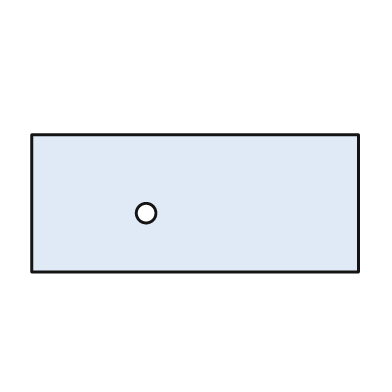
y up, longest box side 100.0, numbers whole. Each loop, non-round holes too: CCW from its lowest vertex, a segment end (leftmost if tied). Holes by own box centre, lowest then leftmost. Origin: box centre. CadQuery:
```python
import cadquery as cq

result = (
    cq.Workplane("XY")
    .moveTo(-50.0, -21.0)
    .lineTo(50.0, -21.0)
    .lineTo(50.0, 21.0)
    .lineTo(-50.0, 21.0)
    .close()
    .moveTo(-15.0, -3.0)
    .circle(3.0)
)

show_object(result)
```